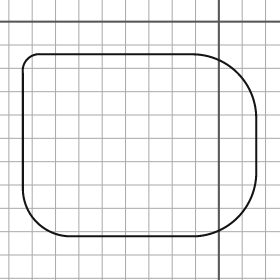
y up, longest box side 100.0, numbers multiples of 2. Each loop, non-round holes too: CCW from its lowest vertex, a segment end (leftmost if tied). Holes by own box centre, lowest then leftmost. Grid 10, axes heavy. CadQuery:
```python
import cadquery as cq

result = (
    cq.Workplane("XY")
    .moveTo(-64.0, -92.0)
    .lineTo(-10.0, -92.0)
    .threePointArc((8.0, -84.0), (16.0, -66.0))
    .lineTo(16.0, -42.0)
    .threePointArc((8.0, -22.0), (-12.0, -14.0))
    .lineTo(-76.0, -14.0)
    .threePointArc((-82.0, -16.0), (-84.0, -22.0))
    .lineTo(-84.0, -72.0)
    .threePointArc((-78.0, -86.0), (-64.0, -92.0))
    .close()
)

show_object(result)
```